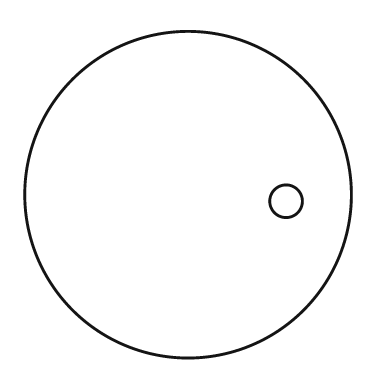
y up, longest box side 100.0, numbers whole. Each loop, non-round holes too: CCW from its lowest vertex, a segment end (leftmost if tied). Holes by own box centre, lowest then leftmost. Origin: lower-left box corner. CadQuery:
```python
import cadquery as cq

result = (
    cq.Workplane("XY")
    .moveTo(50.0, 50.0)
    .circle(50.0)
    .moveTo(80.0, 48.0)
    .circle(5.0)
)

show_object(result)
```